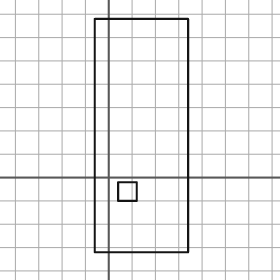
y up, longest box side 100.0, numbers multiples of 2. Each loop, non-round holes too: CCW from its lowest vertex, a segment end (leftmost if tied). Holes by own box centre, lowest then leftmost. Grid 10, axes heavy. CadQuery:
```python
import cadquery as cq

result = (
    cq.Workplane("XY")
    .moveTo(-6.0, -32.0)
    .lineTo(34.0, -32.0)
    .lineTo(34.0, 68.0)
    .lineTo(-6.0, 68.0)
    .close()
    .moveTo(4.0, -10.0)
    .lineTo(12.0, -10.0)
    .lineTo(12.0, -2.0)
    .lineTo(4.0, -2.0)
    .close()
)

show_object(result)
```